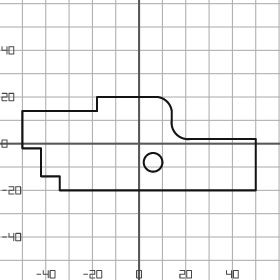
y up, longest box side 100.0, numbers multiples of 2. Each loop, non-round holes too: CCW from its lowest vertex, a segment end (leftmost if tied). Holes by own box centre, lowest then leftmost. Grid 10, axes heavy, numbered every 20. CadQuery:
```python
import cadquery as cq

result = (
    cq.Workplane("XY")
    .moveTo(-34.0, -20.0)
    .lineTo(50.0, -20.0)
    .lineTo(50.0, 2.0)
    .lineTo(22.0, 2.0)
    .threePointArc((16.0, 4.0), (14.0, 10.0))
    .lineTo(14.0, 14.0)
    .threePointArc((12.0, 18.0), (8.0, 20.0))
    .lineTo(-18.0, 20.0)
    .lineTo(-18.0, 14.0)
    .lineTo(-50.0, 14.0)
    .lineTo(-50.0, -2.0)
    .lineTo(-42.0, -2.0)
    .lineTo(-42.0, -14.0)
    .lineTo(-34.0, -14.0)
    .close()
    .moveTo(6.0, -8.0)
    .circle(4.0)
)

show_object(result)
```